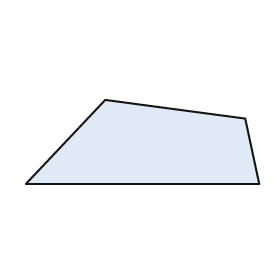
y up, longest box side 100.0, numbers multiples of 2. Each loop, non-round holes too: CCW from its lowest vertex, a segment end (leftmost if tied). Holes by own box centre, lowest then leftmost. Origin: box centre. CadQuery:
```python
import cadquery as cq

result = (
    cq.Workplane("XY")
    .moveTo(-50.0, -18.0)
    .lineTo(50.0, -18.0)
    .lineTo(44.0, 10.0)
    .lineTo(-16.0, 18.0)
    .close()
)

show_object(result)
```